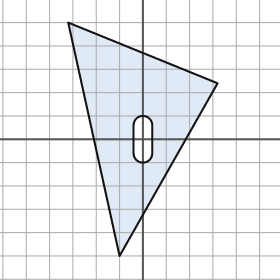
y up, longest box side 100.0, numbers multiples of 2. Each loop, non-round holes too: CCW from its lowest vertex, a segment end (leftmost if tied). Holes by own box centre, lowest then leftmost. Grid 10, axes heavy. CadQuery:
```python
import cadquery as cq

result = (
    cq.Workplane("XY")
    .moveTo(-10.0, -50.0)
    .lineTo(32.0, 24.0)
    .lineTo(-32.0, 50.0)
    .close()
    .moveTo(-4.0, -6.0)
    .threePointArc((0.0, -10.0), (4.0, -6.0))
    .lineTo(4.0, 6.0)
    .threePointArc((0.0, 10.0), (-4.0, 6.0))
    .close()
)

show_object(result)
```